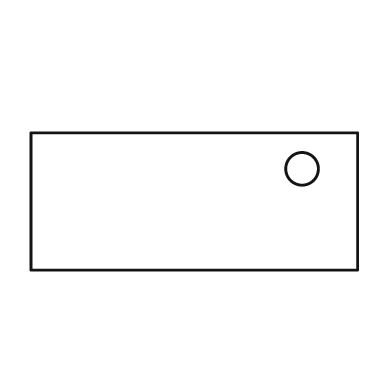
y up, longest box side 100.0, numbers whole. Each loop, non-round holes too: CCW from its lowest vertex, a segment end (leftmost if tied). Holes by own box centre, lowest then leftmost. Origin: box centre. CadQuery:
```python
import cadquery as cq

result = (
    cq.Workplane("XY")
    .moveTo(-50.0, -21.0)
    .lineTo(50.0, -21.0)
    .lineTo(50.0, 21.0)
    .lineTo(-50.0, 21.0)
    .close()
    .moveTo(33.0, 10.0)
    .circle(5.0)
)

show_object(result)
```